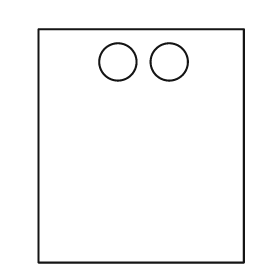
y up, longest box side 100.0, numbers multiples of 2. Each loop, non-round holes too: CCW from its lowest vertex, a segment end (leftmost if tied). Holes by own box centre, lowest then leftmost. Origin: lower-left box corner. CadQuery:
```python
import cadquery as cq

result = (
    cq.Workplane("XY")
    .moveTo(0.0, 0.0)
    .lineTo(88.0, 0.0)
    .lineTo(88.0, 100.0)
    .lineTo(0.0, 100.0)
    .close()
    .moveTo(34.0, 86.0)
    .circle(8.0)
    .moveTo(56.0, 86.0)
    .circle(8.0)
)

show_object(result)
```